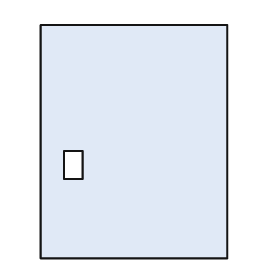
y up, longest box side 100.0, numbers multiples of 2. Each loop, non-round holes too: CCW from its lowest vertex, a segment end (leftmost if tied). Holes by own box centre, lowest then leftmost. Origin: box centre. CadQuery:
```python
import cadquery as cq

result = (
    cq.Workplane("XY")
    .moveTo(-40.0, -50.0)
    .lineTo(40.0, -50.0)
    .lineTo(40.0, 50.0)
    .lineTo(-40.0, 50.0)
    .close()
    .moveTo(-30.0, -16.0)
    .lineTo(-22.0, -16.0)
    .lineTo(-22.0, -4.0)
    .lineTo(-30.0, -4.0)
    .close()
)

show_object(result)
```